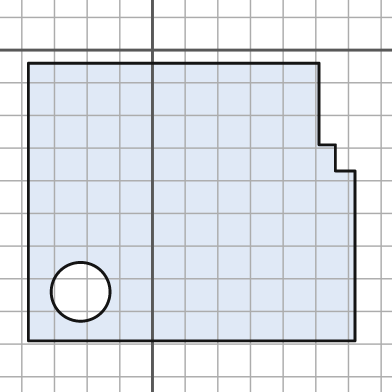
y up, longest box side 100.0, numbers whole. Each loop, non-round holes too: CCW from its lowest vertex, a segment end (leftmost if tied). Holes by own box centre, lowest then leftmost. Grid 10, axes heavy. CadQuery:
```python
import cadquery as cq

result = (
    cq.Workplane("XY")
    .moveTo(-38.0, -89.0)
    .lineTo(62.0, -89.0)
    .lineTo(62.0, -37.0)
    .lineTo(56.0, -37.0)
    .lineTo(56.0, -29.0)
    .lineTo(51.0, -29.0)
    .lineTo(51.0, -4.0)
    .lineTo(-38.0, -4.0)
    .close()
    .moveTo(-22.0, -74.0)
    .circle(9.0)
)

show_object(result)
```